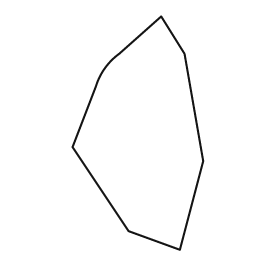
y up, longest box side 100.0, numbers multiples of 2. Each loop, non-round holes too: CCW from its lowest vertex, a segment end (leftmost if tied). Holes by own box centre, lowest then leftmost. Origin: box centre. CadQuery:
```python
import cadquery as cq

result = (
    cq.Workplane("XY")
    .moveTo(18.0, -50.0)
    .lineTo(28.0, -12.0)
    .lineTo(20.0, 34.0)
    .lineTo(10.0, 50.0)
    .lineTo(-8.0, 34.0)
    .threePointArc((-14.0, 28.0), (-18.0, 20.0))
    .lineTo(-28.0, -6.0)
    .lineTo(-4.0, -42.0)
    .close()
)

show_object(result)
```